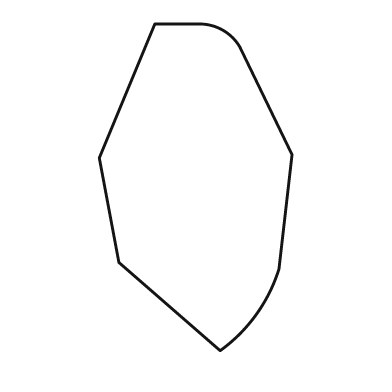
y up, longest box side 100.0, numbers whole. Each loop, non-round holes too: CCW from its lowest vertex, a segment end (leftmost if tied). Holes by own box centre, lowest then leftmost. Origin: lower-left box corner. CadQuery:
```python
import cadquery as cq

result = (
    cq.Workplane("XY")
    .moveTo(37.0, 0.0)
    .threePointArc((48.0, 11.0), (55.0, 25.0))
    .lineTo(59.0, 60.0)
    .lineTo(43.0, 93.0)
    .threePointArc((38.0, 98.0), (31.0, 100.0))
    .lineTo(17.0, 100.0)
    .lineTo(0.0, 59.0)
    .lineTo(6.0, 27.0)
    .close()
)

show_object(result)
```